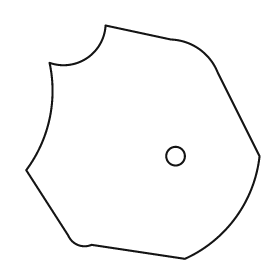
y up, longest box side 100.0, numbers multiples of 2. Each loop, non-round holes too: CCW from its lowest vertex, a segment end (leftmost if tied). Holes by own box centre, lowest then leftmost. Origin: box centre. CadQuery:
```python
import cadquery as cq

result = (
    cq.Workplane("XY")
    .moveTo(18.0, -50.0)
    .threePointArc((40.0, -32.0), (50.0, -6.0))
    .lineTo(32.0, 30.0)
    .threePointArc((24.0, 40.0), (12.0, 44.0))
    .lineTo(-16.0, 50.0)
    .threePointArc((-24.0, 36.0), (-40.0, 34.0))
    .threePointArc((-40.0, 10.0), (-50.0, -12.0))
    .lineTo(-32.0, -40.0)
    .threePointArc((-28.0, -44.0), (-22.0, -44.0))
    .close()
    .moveTo(14.0, -6.0)
    .circle(4.0)
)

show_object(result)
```